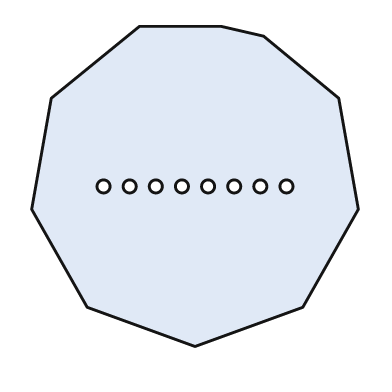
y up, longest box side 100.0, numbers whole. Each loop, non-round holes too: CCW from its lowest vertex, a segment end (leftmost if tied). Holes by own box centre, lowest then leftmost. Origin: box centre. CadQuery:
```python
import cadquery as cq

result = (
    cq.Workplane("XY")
    .moveTo(0.0, -49.0)
    .lineTo(33.0, -37.0)
    .lineTo(50.0, -7.0)
    .lineTo(44.0, 27.0)
    .lineTo(21.0, 46.0)
    .lineTo(8.0, 49.0)
    .lineTo(-17.0, 49.0)
    .lineTo(-44.0, 27.0)
    .lineTo(-50.0, -7.0)
    .lineTo(-33.0, -37.0)
    .close()
    .moveTo(-28.0, 0.0)
    .circle(2.0)
    .moveTo(-20.0, 0.0)
    .circle(2.0)
    .moveTo(-12.0, 0.0)
    .circle(2.0)
    .moveTo(-4.0, 0.0)
    .circle(2.0)
    .moveTo(4.0, 0.0)
    .circle(2.0)
    .moveTo(12.0, 0.0)
    .circle(2.0)
    .moveTo(20.0, 0.0)
    .circle(2.0)
    .moveTo(28.0, 0.0)
    .circle(2.0)
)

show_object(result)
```